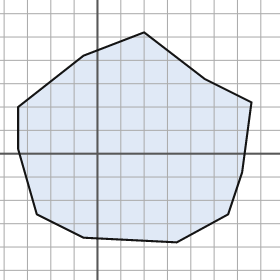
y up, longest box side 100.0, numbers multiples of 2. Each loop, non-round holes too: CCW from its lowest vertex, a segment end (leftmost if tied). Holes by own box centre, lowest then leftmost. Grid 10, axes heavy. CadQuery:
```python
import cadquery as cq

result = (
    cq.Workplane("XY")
    .moveTo(34.0, -38.0)
    .lineTo(56.0, -26.0)
    .lineTo(62.0, -8.0)
    .lineTo(66.0, 22.0)
    .lineTo(46.0, 32.0)
    .lineTo(20.0, 52.0)
    .lineTo(-6.0, 42.0)
    .lineTo(-34.0, 20.0)
    .lineTo(-34.0, 2.0)
    .lineTo(-26.0, -26.0)
    .lineTo(-6.0, -36.0)
    .close()
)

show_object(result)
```